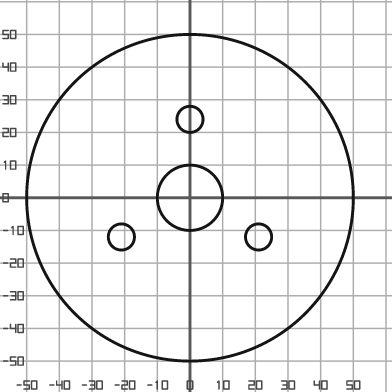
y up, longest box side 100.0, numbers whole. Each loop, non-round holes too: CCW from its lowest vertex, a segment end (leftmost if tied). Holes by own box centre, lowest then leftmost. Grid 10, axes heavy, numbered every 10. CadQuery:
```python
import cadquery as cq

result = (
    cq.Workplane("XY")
    .moveTo(0.0, 0.0)
    .circle(50.0)
    .moveTo(-21.0, -12.0)
    .circle(4.0)
    .moveTo(21.0, -12.0)
    .circle(4.0)
    .moveTo(0.0, 0.0)
    .circle(10.0)
    .moveTo(0.0, 24.0)
    .circle(4.0)
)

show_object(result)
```